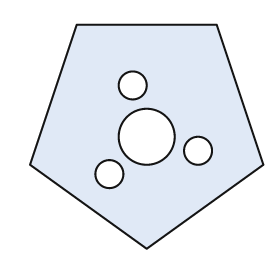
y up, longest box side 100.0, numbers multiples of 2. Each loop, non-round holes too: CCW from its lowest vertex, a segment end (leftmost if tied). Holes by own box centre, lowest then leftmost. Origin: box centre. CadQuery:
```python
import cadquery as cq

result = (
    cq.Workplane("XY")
    .moveTo(0.0, -48.0)
    .lineTo(50.0, -12.0)
    .lineTo(30.0, 48.0)
    .lineTo(-30.0, 48.0)
    .lineTo(-50.0, -12.0)
    .close()
    .moveTo(-16.0, -16.0)
    .circle(6.0)
    .moveTo(22.0, -6.0)
    .circle(6.0)
    .moveTo(0.0, 0.0)
    .circle(12.0)
    .moveTo(-6.0, 22.0)
    .circle(6.0)
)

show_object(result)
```